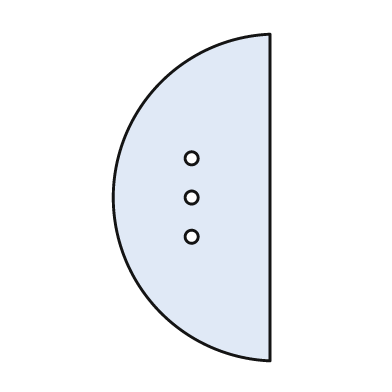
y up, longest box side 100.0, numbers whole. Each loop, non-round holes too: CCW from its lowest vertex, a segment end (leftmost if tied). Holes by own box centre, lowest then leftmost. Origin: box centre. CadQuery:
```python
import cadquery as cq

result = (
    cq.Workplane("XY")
    .moveTo(24.0, -50.0)
    .lineTo(24.0, 50.0)
    .threePointArc((-24.0, 0.0), (24.0, -50.0))
    .close()
    .moveTo(0.0, -12.0)
    .circle(2.0)
    .moveTo(0.0, 0.0)
    .circle(2.0)
    .moveTo(0.0, 12.0)
    .circle(2.0)
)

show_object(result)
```